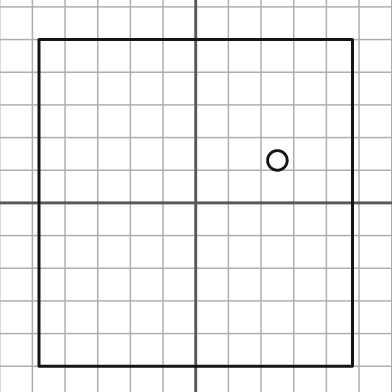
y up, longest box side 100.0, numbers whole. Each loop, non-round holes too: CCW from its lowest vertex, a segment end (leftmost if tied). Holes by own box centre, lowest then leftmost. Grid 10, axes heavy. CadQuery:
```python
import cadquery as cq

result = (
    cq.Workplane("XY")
    .moveTo(-48.0, -50.0)
    .lineTo(48.0, -50.0)
    .lineTo(48.0, 50.0)
    .lineTo(-48.0, 50.0)
    .close()
    .moveTo(25.0, 13.0)
    .circle(3.0)
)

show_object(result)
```